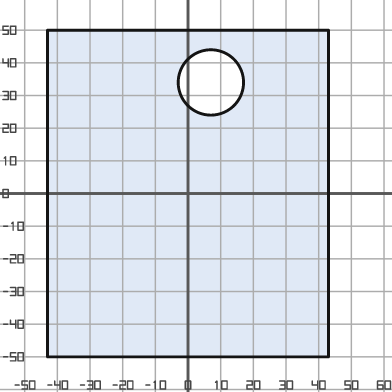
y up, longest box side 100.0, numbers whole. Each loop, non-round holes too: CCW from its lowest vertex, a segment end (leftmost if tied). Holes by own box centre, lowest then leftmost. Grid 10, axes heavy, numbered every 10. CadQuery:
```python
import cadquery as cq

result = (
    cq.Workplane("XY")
    .moveTo(-43.0, -50.0)
    .lineTo(43.0, -50.0)
    .lineTo(43.0, 50.0)
    .lineTo(-43.0, 50.0)
    .close()
    .moveTo(7.0, 34.0)
    .circle(10.0)
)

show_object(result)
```